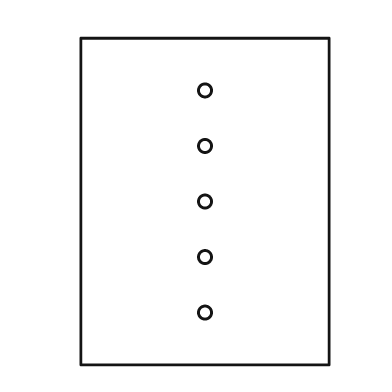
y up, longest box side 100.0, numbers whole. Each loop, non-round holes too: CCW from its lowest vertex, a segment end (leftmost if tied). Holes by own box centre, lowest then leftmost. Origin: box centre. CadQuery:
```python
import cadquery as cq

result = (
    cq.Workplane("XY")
    .moveTo(-38.0, -50.0)
    .lineTo(38.0, -50.0)
    .lineTo(38.0, 50.0)
    .lineTo(-38.0, 50.0)
    .close()
    .moveTo(0.0, -34.0)
    .circle(2.0)
    .moveTo(0.0, -17.0)
    .circle(2.0)
    .moveTo(0.0, 0.0)
    .circle(2.0)
    .moveTo(0.0, 17.0)
    .circle(2.0)
    .moveTo(0.0, 34.0)
    .circle(2.0)
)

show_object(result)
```